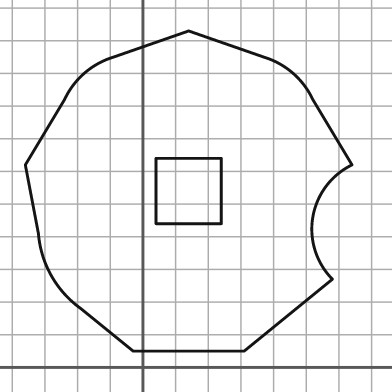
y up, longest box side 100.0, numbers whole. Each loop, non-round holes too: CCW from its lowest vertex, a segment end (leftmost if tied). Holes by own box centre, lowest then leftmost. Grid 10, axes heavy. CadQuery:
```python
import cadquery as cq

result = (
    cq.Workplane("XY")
    .moveTo(-3.0, 5.0)
    .lineTo(31.0, 5.0)
    .lineTo(58.0, 27.0)
    .threePointArc((52.0, 46.0), (64.0, 62.0))
    .lineTo(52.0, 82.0)
    .threePointArc((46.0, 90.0), (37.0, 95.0))
    .lineTo(14.0, 103.0)
    .lineTo(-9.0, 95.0)
    .threePointArc((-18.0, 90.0), (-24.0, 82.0))
    .lineTo(-36.0, 62.0)
    .lineTo(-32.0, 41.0)
    .threePointArc((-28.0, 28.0), (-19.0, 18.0))
    .close()
    .moveTo(4.0, 44.0)
    .lineTo(24.0, 44.0)
    .lineTo(24.0, 64.0)
    .lineTo(4.0, 64.0)
    .close()
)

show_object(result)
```